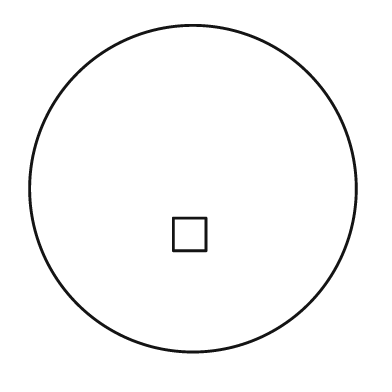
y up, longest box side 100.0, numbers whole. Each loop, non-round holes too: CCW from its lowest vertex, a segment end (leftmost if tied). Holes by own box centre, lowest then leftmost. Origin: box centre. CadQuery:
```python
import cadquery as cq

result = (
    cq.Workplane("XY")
    .moveTo(0.0, 0.0)
    .circle(50.0)
    .moveTo(-6.0, -19.0)
    .lineTo(4.0, -19.0)
    .lineTo(4.0, -9.0)
    .lineTo(-6.0, -9.0)
    .close()
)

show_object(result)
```